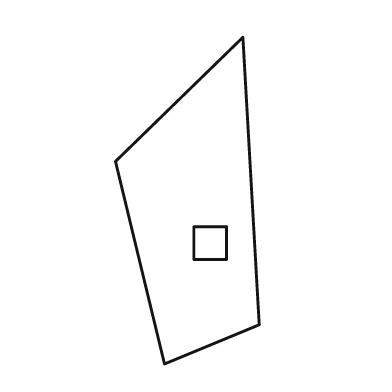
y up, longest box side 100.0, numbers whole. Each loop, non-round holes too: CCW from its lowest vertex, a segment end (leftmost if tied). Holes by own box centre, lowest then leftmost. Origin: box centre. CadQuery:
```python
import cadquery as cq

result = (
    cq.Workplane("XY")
    .moveTo(-7.0, -50.0)
    .lineTo(22.0, -38.0)
    .lineTo(17.0, 50.0)
    .lineTo(-22.0, 12.0)
    .close()
    .moveTo(2.0, -18.0)
    .lineTo(12.0, -18.0)
    .lineTo(12.0, -8.0)
    .lineTo(2.0, -8.0)
    .close()
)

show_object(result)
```